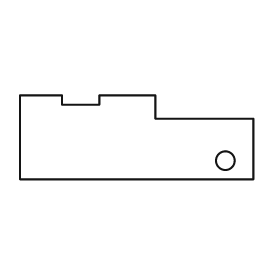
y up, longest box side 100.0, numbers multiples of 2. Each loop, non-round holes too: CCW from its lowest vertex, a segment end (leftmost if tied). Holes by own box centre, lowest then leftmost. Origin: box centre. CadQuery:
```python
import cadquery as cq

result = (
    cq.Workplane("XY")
    .moveTo(-50.0, -18.0)
    .lineTo(50.0, -18.0)
    .lineTo(50.0, 8.0)
    .lineTo(8.0, 8.0)
    .lineTo(8.0, 18.0)
    .lineTo(-16.0, 18.0)
    .lineTo(-16.0, 14.0)
    .lineTo(-32.0, 14.0)
    .lineTo(-32.0, 18.0)
    .lineTo(-50.0, 18.0)
    .close()
    .moveTo(38.0, -10.0)
    .circle(4.0)
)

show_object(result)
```